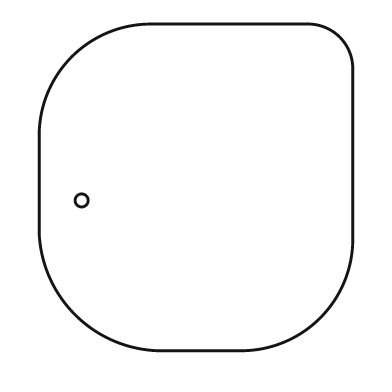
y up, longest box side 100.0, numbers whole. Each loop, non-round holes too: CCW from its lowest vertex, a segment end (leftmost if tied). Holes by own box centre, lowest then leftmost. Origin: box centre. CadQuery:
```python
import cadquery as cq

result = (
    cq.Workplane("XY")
    .moveTo(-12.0, -50.0)
    .lineTo(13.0, -50.0)
    .threePointArc((38.0, -40.0), (48.0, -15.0))
    .lineTo(48.0, 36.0)
    .threePointArc((44.0, 46.0), (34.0, 50.0))
    .lineTo(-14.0, 50.0)
    .threePointArc((-38.0, 40.0), (-48.0, 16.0))
    .lineTo(-48.0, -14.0)
    .threePointArc((-37.0, -39.0), (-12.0, -50.0))
    .close()
    .moveTo(-35.0, -4.0)
    .circle(2.0)
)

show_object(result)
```